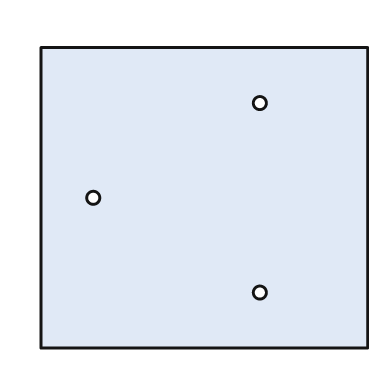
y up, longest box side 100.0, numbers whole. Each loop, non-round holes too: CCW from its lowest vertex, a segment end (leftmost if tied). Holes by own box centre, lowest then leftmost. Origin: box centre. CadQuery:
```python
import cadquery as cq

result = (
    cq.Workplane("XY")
    .moveTo(-50.0, -46.0)
    .lineTo(50.0, -46.0)
    .lineTo(50.0, 46.0)
    .lineTo(-50.0, 46.0)
    .close()
    .moveTo(17.0, -29.0)
    .circle(2.0)
    .moveTo(-34.0, 0.0)
    .circle(2.0)
    .moveTo(17.0, 29.0)
    .circle(2.0)
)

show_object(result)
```